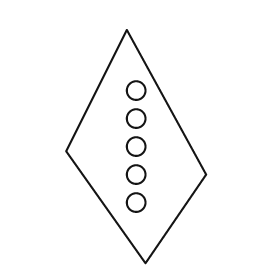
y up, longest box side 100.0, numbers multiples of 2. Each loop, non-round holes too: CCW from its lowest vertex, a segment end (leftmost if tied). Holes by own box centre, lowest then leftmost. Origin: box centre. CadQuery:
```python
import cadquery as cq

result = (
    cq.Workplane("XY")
    .moveTo(4.0, -50.0)
    .lineTo(30.0, -12.0)
    .lineTo(-4.0, 50.0)
    .lineTo(-30.0, -2.0)
    .close()
    .moveTo(0.0, -24.0)
    .circle(4.0)
    .moveTo(0.0, -12.0)
    .circle(4.0)
    .moveTo(0.0, 0.0)
    .circle(4.0)
    .moveTo(0.0, 12.0)
    .circle(4.0)
    .moveTo(0.0, 24.0)
    .circle(4.0)
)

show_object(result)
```